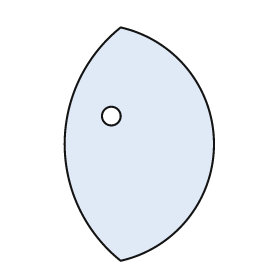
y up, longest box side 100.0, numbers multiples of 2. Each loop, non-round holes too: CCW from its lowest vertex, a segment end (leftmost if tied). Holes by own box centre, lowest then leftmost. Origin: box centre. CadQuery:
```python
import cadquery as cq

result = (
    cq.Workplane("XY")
    .moveTo(-8.0, -50.0)
    .threePointArc((32.0, 0.0), (-8.0, 50.0))
    .threePointArc((-32.0, 0.0), (-8.0, -50.0))
    .close()
    .moveTo(-12.0, 12.0)
    .circle(4.0)
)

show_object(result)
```